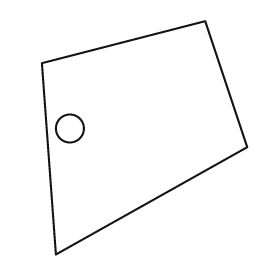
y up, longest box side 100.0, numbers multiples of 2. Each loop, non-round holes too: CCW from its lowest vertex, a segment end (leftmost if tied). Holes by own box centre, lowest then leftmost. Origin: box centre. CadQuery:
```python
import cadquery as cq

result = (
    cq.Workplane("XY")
    .moveTo(-38.0, -50.0)
    .lineTo(44.0, -4.0)
    .lineTo(26.0, 50.0)
    .lineTo(-44.0, 32.0)
    .close()
    .moveTo(-32.0, 4.0)
    .circle(6.0)
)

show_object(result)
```